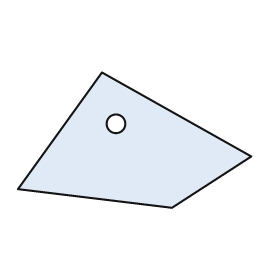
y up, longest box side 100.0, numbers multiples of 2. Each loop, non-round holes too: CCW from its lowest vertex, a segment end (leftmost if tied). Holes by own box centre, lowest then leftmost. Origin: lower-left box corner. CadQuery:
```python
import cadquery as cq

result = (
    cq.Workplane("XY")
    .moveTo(66.0, 0.0)
    .lineTo(100.0, 22.0)
    .lineTo(36.0, 58.0)
    .lineTo(0.0, 8.0)
    .close()
    .moveTo(42.0, 36.0)
    .circle(4.0)
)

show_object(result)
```